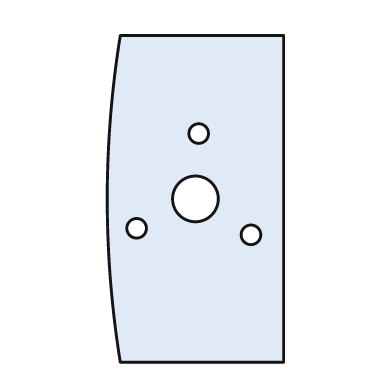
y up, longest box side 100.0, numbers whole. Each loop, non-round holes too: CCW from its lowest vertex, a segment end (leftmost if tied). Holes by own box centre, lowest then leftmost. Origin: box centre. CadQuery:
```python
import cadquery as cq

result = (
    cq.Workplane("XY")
    .moveTo(-23.0, -50.0)
    .lineTo(27.0, -50.0)
    .lineTo(27.0, 50.0)
    .lineTo(-23.0, 50.0)
    .threePointArc((-27.0, 0.0), (-23.0, -50.0))
    .close()
    .moveTo(17.0, -11.0)
    .circle(3.0)
    .moveTo(-18.0, -9.0)
    .circle(3.0)
    .moveTo(0.0, 0.0)
    .circle(7.0)
    .moveTo(1.0, 20.0)
    .circle(3.0)
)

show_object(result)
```